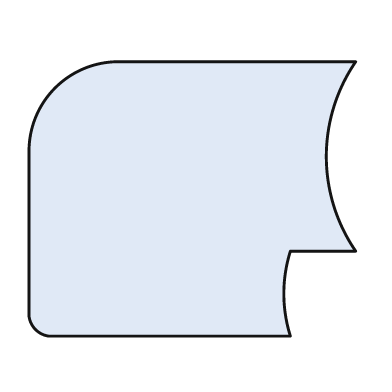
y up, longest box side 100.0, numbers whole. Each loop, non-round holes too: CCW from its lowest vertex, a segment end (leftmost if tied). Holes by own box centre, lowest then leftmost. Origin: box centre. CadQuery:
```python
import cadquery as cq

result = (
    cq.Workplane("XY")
    .moveTo(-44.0, -42.0)
    .lineTo(30.0, -42.0)
    .threePointArc((28.0, -29.0), (30.0, -16.0))
    .lineTo(50.0, -16.0)
    .threePointArc((41.0, 13.0), (50.0, 42.0))
    .lineTo(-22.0, 42.0)
    .threePointArc((-42.0, 34.0), (-50.0, 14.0))
    .lineTo(-50.0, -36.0)
    .threePointArc((-48.0, -40.0), (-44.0, -42.0))
    .close()
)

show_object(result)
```